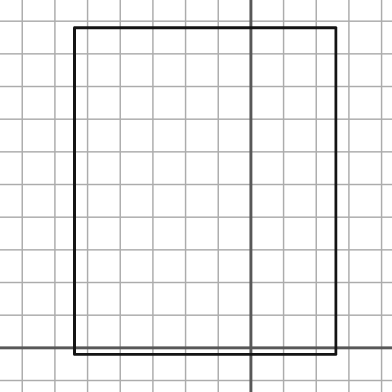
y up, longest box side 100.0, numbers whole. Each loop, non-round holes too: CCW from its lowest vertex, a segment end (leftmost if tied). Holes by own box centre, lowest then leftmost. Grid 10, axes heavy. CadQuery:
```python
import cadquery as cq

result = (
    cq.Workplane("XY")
    .moveTo(-54.0, -2.0)
    .lineTo(26.0, -2.0)
    .lineTo(26.0, 98.0)
    .lineTo(-54.0, 98.0)
    .close()
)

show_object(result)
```